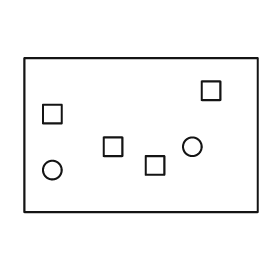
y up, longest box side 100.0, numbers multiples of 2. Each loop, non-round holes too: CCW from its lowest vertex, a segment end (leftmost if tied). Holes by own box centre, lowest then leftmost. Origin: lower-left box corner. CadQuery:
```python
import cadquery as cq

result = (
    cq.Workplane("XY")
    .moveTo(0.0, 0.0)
    .lineTo(100.0, 0.0)
    .lineTo(100.0, 66.0)
    .lineTo(0.0, 66.0)
    .close()
    .moveTo(12.0, 18.0)
    .circle(4.0)
    .moveTo(52.0, 16.0)
    .lineTo(60.0, 16.0)
    .lineTo(60.0, 24.0)
    .lineTo(52.0, 24.0)
    .close()
    .moveTo(34.0, 24.0)
    .lineTo(42.0, 24.0)
    .lineTo(42.0, 32.0)
    .lineTo(34.0, 32.0)
    .close()
    .moveTo(72.0, 28.0)
    .circle(4.0)
    .moveTo(8.0, 38.0)
    .lineTo(16.0, 38.0)
    .lineTo(16.0, 46.0)
    .lineTo(8.0, 46.0)
    .close()
    .moveTo(76.0, 48.0)
    .lineTo(84.0, 48.0)
    .lineTo(84.0, 56.0)
    .lineTo(76.0, 56.0)
    .close()
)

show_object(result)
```